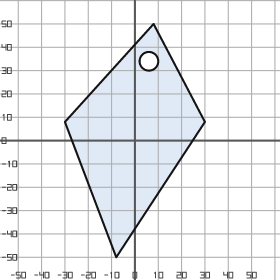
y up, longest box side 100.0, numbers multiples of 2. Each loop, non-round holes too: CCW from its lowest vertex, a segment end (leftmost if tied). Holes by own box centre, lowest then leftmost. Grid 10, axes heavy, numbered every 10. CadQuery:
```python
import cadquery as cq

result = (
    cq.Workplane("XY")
    .moveTo(-8.0, -50.0)
    .lineTo(30.0, 8.0)
    .lineTo(8.0, 50.0)
    .lineTo(-30.0, 8.0)
    .close()
    .moveTo(6.0, 34.0)
    .circle(4.0)
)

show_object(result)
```